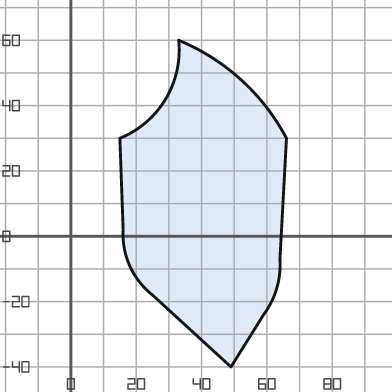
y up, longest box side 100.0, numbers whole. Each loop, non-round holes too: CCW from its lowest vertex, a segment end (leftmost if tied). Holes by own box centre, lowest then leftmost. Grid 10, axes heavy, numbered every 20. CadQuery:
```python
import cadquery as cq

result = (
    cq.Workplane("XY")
    .moveTo(49.0, -40.0)
    .lineTo(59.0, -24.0)
    .threePointArc((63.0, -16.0), (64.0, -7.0))
    .lineTo(66.0, 30.0)
    .threePointArc((52.0, 48.0), (33.0, 60.0))
    .threePointArc((29.0, 42.0), (15.0, 30.0))
    .lineTo(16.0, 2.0)
    .threePointArc((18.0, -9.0), (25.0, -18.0))
    .close()
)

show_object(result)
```